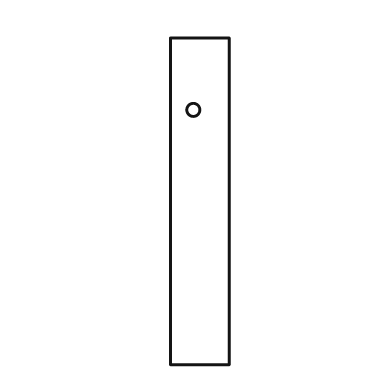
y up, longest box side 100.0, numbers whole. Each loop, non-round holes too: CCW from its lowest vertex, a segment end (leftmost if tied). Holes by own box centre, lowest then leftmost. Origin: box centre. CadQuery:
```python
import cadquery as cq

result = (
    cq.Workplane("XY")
    .moveTo(-9.0, -50.0)
    .lineTo(9.0, -50.0)
    .lineTo(9.0, 50.0)
    .lineTo(-9.0, 50.0)
    .close()
    .moveTo(-2.0, 28.0)
    .circle(2.0)
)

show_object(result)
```